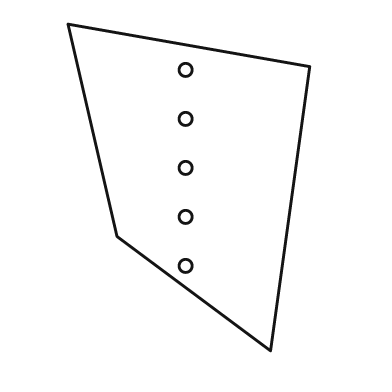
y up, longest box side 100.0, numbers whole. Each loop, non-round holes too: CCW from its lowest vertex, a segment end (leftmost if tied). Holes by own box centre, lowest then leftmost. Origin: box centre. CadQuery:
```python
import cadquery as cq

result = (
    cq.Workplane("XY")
    .moveTo(25.0, -50.0)
    .lineTo(37.0, 37.0)
    .lineTo(-37.0, 50.0)
    .lineTo(-22.0, -15.0)
    .close()
    .moveTo(-1.0, -24.0)
    .circle(2.0)
    .moveTo(-1.0, -9.0)
    .circle(2.0)
    .moveTo(-1.0, 6.0)
    .circle(2.0)
    .moveTo(-1.0, 21.0)
    .circle(2.0)
    .moveTo(-1.0, 36.0)
    .circle(2.0)
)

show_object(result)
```